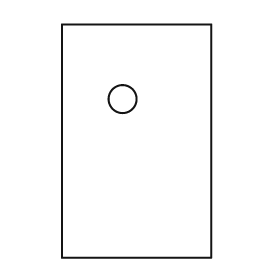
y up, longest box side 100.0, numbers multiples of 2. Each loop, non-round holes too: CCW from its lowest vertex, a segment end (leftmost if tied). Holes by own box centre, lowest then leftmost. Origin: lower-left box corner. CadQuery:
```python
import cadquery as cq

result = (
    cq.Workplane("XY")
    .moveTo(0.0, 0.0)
    .lineTo(64.0, 0.0)
    .lineTo(64.0, 100.0)
    .lineTo(0.0, 100.0)
    .close()
    .moveTo(26.0, 68.0)
    .circle(6.0)
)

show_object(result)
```